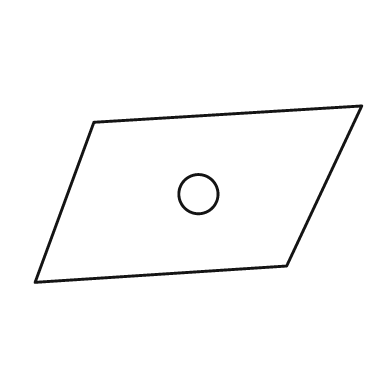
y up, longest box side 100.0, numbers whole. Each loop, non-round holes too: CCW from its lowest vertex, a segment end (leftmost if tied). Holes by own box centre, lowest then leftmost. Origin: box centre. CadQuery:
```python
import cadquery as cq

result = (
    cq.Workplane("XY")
    .moveTo(-50.0, -27.0)
    .lineTo(27.0, -22.0)
    .lineTo(50.0, 27.0)
    .lineTo(-32.0, 22.0)
    .close()
    .moveTo(0.0, 0.0)
    .circle(6.0)
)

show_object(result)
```